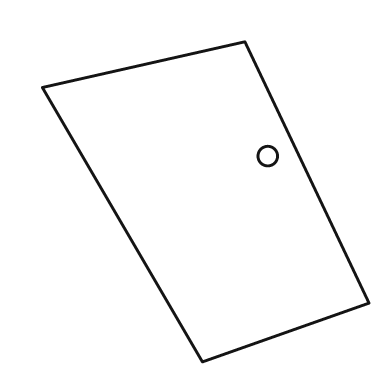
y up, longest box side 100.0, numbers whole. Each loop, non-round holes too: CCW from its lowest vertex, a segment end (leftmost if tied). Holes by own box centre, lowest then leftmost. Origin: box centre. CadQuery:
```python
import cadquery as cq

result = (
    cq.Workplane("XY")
    .moveTo(-1.0, -49.0)
    .lineTo(50.0, -31.0)
    .lineTo(12.0, 49.0)
    .lineTo(-50.0, 35.0)
    .close()
    .moveTo(19.0, 14.0)
    .circle(3.0)
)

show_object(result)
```